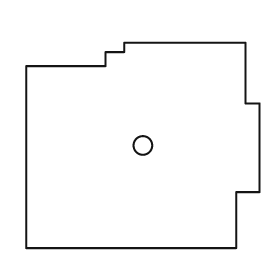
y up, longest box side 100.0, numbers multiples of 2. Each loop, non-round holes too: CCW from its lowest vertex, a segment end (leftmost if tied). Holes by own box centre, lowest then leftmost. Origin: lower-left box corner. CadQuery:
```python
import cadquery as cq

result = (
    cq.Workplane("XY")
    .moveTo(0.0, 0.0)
    .lineTo(90.0, 0.0)
    .lineTo(90.0, 24.0)
    .lineTo(100.0, 24.0)
    .lineTo(100.0, 62.0)
    .lineTo(94.0, 62.0)
    .lineTo(94.0, 88.0)
    .lineTo(42.0, 88.0)
    .lineTo(42.0, 84.0)
    .lineTo(34.0, 84.0)
    .lineTo(34.0, 78.0)
    .lineTo(0.0, 78.0)
    .close()
    .moveTo(50.0, 44.0)
    .circle(4.0)
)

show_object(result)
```